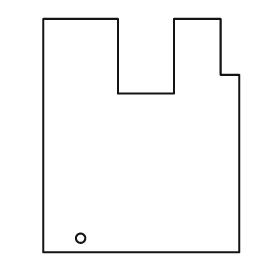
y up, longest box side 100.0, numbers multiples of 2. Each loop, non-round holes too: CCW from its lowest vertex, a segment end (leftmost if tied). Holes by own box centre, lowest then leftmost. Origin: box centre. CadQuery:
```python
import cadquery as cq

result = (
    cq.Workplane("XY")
    .moveTo(-42.0, -50.0)
    .lineTo(42.0, -50.0)
    .lineTo(42.0, 26.0)
    .lineTo(34.0, 26.0)
    .lineTo(34.0, 50.0)
    .lineTo(14.0, 50.0)
    .lineTo(14.0, 18.0)
    .lineTo(-10.0, 18.0)
    .lineTo(-10.0, 50.0)
    .lineTo(-42.0, 50.0)
    .close()
    .moveTo(-26.0, -44.0)
    .circle(2.0)
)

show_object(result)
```